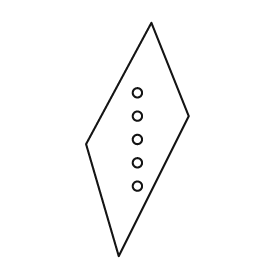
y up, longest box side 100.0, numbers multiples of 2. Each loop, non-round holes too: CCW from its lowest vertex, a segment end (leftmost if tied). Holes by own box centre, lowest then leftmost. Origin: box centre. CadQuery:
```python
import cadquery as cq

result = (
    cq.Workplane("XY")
    .moveTo(-8.0, -50.0)
    .lineTo(22.0, 10.0)
    .lineTo(6.0, 50.0)
    .lineTo(-22.0, -2.0)
    .close()
    .moveTo(0.0, -20.0)
    .circle(2.0)
    .moveTo(0.0, -10.0)
    .circle(2.0)
    .moveTo(0.0, 0.0)
    .circle(2.0)
    .moveTo(0.0, 10.0)
    .circle(2.0)
    .moveTo(0.0, 20.0)
    .circle(2.0)
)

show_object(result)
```